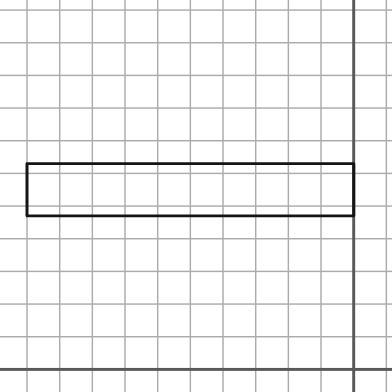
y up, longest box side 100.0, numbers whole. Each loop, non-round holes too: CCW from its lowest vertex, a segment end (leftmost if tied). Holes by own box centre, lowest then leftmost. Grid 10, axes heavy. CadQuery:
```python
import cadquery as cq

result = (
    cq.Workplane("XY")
    .moveTo(-100.0, 47.0)
    .lineTo(0.0, 47.0)
    .lineTo(0.0, 63.0)
    .lineTo(-100.0, 63.0)
    .close()
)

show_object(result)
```